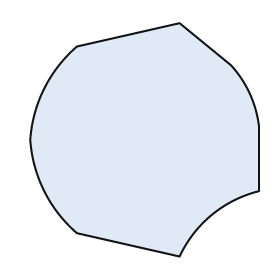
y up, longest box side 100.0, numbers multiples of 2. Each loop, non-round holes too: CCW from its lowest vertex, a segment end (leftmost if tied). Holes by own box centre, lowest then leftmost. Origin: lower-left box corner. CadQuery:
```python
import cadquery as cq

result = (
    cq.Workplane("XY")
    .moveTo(64.0, 0.0)
    .threePointArc((78.0, 18.0), (98.0, 28.0))
    .lineTo(98.0, 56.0)
    .threePointArc((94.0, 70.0), (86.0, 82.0))
    .lineTo(64.0, 100.0)
    .lineTo(20.0, 90.0)
    .threePointArc((6.0, 72.0), (0.0, 50.0))
    .threePointArc((6.0, 28.0), (20.0, 10.0))
    .close()
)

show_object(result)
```